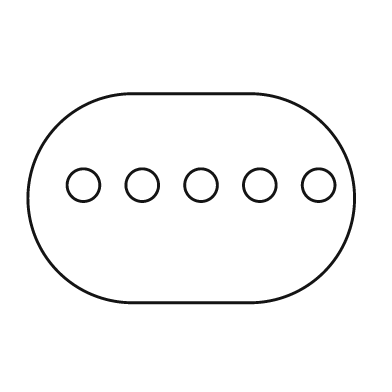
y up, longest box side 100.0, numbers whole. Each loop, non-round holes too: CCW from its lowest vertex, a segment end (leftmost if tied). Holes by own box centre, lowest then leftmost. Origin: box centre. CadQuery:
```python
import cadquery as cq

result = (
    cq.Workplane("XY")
    .moveTo(-18.0, -32.0)
    .lineTo(18.0, -32.0)
    .threePointArc((50.0, 0.0), (18.0, 32.0))
    .lineTo(-18.0, 32.0)
    .threePointArc((-50.0, 0.0), (-18.0, -32.0))
    .close()
    .moveTo(-33.0, 4.0)
    .circle(5.0)
    .moveTo(-15.0, 4.0)
    .circle(5.0)
    .moveTo(3.0, 4.0)
    .circle(5.0)
    .moveTo(21.0, 4.0)
    .circle(5.0)
    .moveTo(39.0, 4.0)
    .circle(5.0)
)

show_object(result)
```